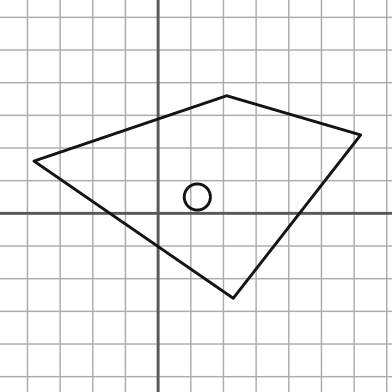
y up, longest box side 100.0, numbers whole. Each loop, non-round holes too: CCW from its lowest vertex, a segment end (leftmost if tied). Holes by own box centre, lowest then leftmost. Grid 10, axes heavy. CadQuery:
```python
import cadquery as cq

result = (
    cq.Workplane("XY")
    .moveTo(23.0, -26.0)
    .lineTo(62.0, 24.0)
    .lineTo(21.0, 36.0)
    .lineTo(-38.0, 16.0)
    .close()
    .moveTo(12.0, 5.0)
    .circle(4.0)
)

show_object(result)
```